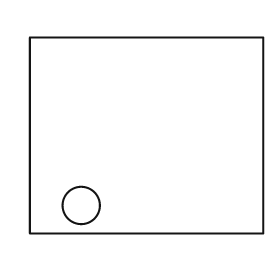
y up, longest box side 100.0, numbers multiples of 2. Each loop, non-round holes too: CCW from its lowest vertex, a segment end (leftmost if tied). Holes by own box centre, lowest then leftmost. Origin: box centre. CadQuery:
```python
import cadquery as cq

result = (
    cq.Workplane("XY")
    .moveTo(-50.0, -42.0)
    .lineTo(50.0, -42.0)
    .lineTo(50.0, 42.0)
    .lineTo(-50.0, 42.0)
    .close()
    .moveTo(-28.0, -30.0)
    .circle(8.0)
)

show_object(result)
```